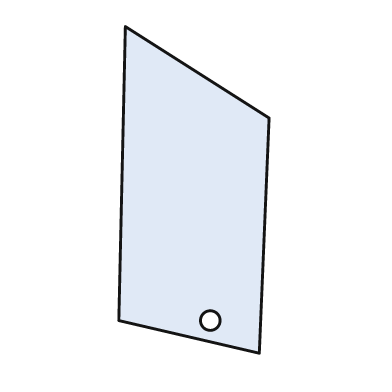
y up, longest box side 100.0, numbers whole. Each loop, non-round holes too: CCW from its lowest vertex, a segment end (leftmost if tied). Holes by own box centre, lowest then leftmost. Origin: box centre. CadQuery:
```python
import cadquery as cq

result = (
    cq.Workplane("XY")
    .moveTo(20.0, -50.0)
    .lineTo(23.0, 22.0)
    .lineTo(-21.0, 50.0)
    .lineTo(-23.0, -40.0)
    .close()
    .moveTo(5.0, -40.0)
    .circle(3.0)
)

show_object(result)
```